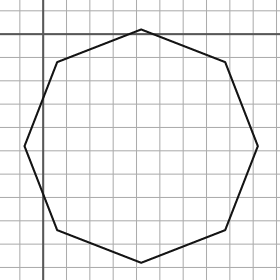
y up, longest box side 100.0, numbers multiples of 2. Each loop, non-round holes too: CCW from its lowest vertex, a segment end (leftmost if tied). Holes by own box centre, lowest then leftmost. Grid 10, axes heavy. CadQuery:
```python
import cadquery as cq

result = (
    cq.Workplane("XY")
    .moveTo(42.0, -98.0)
    .lineTo(78.0, -84.0)
    .lineTo(92.0, -48.0)
    .lineTo(78.0, -12.0)
    .lineTo(42.0, 2.0)
    .lineTo(6.0, -12.0)
    .lineTo(-8.0, -48.0)
    .lineTo(6.0, -84.0)
    .close()
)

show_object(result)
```